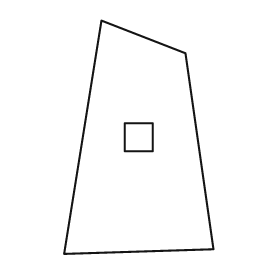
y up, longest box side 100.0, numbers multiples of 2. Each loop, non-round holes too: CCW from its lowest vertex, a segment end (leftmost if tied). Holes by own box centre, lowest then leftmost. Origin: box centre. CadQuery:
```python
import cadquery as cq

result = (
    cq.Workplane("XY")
    .moveTo(-32.0, -50.0)
    .lineTo(32.0, -48.0)
    .lineTo(20.0, 36.0)
    .lineTo(-16.0, 50.0)
    .close()
    .moveTo(-6.0, -6.0)
    .lineTo(6.0, -6.0)
    .lineTo(6.0, 6.0)
    .lineTo(-6.0, 6.0)
    .close()
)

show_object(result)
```